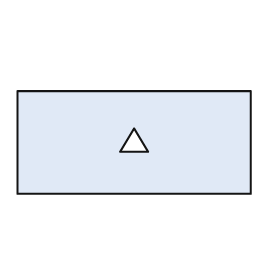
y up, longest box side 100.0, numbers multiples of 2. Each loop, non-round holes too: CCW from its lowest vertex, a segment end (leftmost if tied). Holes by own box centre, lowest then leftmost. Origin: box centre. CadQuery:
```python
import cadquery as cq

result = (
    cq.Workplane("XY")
    .moveTo(-50.0, -22.0)
    .lineTo(50.0, -22.0)
    .lineTo(50.0, 22.0)
    .lineTo(-50.0, 22.0)
    .close()
    .moveTo(-6.0, -4.0)
    .lineTo(6.0, -4.0)
    .lineTo(0.0, 6.0)
    .close()
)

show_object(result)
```